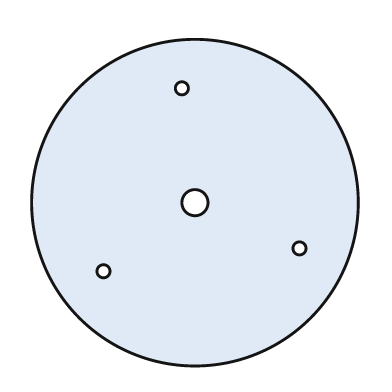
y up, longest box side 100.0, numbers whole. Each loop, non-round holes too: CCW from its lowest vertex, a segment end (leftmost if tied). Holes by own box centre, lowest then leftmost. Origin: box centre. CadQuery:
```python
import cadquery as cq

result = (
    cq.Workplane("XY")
    .moveTo(0.0, 0.0)
    .circle(50.0)
    .moveTo(-28.0, -21.0)
    .circle(2.0)
    .moveTo(32.0, -14.0)
    .circle(2.0)
    .moveTo(0.0, 0.0)
    .circle(4.0)
    .moveTo(-4.0, 35.0)
    .circle(2.0)
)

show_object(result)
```